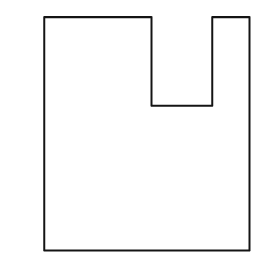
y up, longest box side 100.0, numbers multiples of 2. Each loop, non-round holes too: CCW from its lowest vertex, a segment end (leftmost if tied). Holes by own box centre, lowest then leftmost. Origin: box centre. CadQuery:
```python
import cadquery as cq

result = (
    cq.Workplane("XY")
    .moveTo(-44.0, -50.0)
    .lineTo(44.0, -50.0)
    .lineTo(44.0, 50.0)
    .lineTo(28.0, 50.0)
    .lineTo(28.0, 12.0)
    .lineTo(2.0, 12.0)
    .lineTo(2.0, 50.0)
    .lineTo(-44.0, 50.0)
    .close()
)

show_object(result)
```